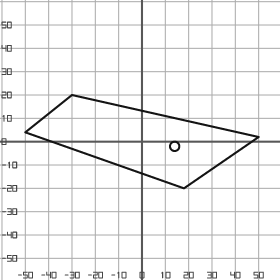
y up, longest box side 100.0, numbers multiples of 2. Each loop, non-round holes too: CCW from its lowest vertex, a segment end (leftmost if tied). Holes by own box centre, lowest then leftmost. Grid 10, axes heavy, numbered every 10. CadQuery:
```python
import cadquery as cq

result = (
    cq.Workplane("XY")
    .moveTo(18.0, -20.0)
    .lineTo(50.0, 2.0)
    .lineTo(-30.0, 20.0)
    .lineTo(-50.0, 4.0)
    .close()
    .moveTo(14.0, -2.0)
    .circle(2.0)
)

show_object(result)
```